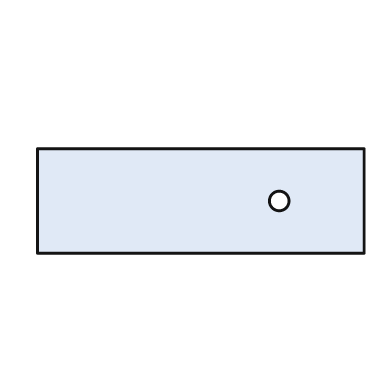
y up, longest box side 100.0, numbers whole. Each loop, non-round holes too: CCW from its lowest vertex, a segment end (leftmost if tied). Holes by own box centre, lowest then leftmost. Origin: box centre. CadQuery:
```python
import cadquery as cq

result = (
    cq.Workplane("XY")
    .moveTo(-50.0, -16.0)
    .lineTo(50.0, -16.0)
    .lineTo(50.0, 16.0)
    .lineTo(-50.0, 16.0)
    .close()
    .moveTo(24.0, 0.0)
    .circle(3.0)
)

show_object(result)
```